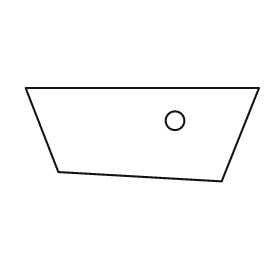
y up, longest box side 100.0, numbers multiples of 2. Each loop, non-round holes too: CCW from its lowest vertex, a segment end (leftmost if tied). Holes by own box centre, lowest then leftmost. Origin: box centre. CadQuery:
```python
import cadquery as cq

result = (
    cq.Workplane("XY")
    .moveTo(34.0, -20.0)
    .lineTo(50.0, 20.0)
    .lineTo(-50.0, 20.0)
    .lineTo(-36.0, -16.0)
    .close()
    .moveTo(14.0, 6.0)
    .circle(4.0)
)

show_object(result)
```